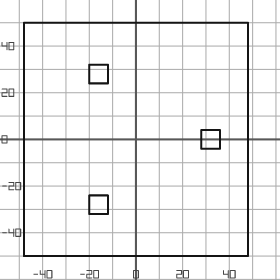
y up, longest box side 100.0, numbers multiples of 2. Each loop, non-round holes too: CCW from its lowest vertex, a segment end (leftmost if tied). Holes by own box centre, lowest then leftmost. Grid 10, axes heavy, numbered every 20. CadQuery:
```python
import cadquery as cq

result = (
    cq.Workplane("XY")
    .moveTo(-48.0, -50.0)
    .lineTo(48.0, -50.0)
    .lineTo(48.0, 50.0)
    .lineTo(-48.0, 50.0)
    .close()
    .moveTo(-20.0, -32.0)
    .lineTo(-12.0, -32.0)
    .lineTo(-12.0, -24.0)
    .lineTo(-20.0, -24.0)
    .close()
    .moveTo(28.0, -4.0)
    .lineTo(36.0, -4.0)
    .lineTo(36.0, 4.0)
    .lineTo(28.0, 4.0)
    .close()
    .moveTo(-20.0, 24.0)
    .lineTo(-12.0, 24.0)
    .lineTo(-12.0, 32.0)
    .lineTo(-20.0, 32.0)
    .close()
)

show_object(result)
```